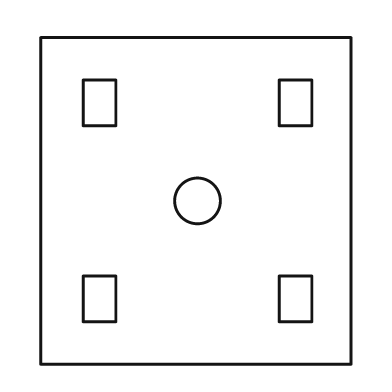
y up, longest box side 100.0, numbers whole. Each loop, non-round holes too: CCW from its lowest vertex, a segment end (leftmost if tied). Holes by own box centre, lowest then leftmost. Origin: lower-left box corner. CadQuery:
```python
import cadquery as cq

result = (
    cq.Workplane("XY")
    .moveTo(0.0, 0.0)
    .lineTo(95.0, 0.0)
    .lineTo(95.0, 100.0)
    .lineTo(0.0, 100.0)
    .close()
    .moveTo(13.0, 13.0)
    .lineTo(23.0, 13.0)
    .lineTo(23.0, 27.0)
    .lineTo(13.0, 27.0)
    .close()
    .moveTo(73.0, 13.0)
    .lineTo(83.0, 13.0)
    .lineTo(83.0, 27.0)
    .lineTo(73.0, 27.0)
    .close()
    .moveTo(48.0, 50.0)
    .circle(7.0)
    .moveTo(13.0, 73.0)
    .lineTo(23.0, 73.0)
    .lineTo(23.0, 87.0)
    .lineTo(13.0, 87.0)
    .close()
    .moveTo(73.0, 73.0)
    .lineTo(83.0, 73.0)
    .lineTo(83.0, 87.0)
    .lineTo(73.0, 87.0)
    .close()
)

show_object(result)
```